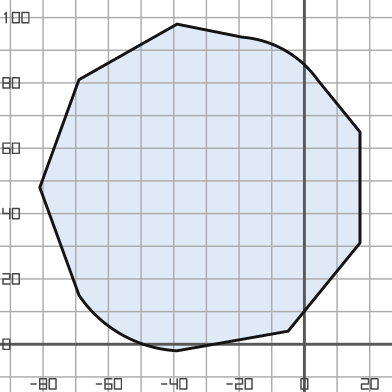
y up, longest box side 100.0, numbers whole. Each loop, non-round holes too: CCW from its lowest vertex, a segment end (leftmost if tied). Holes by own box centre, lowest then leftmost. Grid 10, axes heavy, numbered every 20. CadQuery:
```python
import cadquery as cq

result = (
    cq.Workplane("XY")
    .moveTo(-39.0, -2.0)
    .lineTo(-5.0, 4.0)
    .lineTo(17.0, 31.0)
    .lineTo(17.0, 65.0)
    .lineTo(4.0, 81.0)
    .threePointArc((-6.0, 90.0), (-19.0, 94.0))
    .lineTo(-39.0, 98.0)
    .lineTo(-69.0, 81.0)
    .lineTo(-81.0, 48.0)
    .lineTo(-69.0, 15.0)
    .threePointArc((-56.0, 3.0), (-39.0, -2.0))
    .close()
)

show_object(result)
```